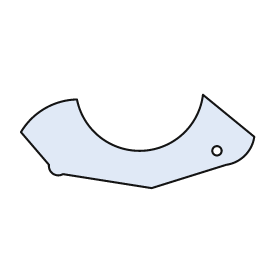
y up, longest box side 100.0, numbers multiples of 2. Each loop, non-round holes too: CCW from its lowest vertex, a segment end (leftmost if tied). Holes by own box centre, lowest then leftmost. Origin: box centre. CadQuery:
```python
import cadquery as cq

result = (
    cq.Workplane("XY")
    .moveTo(6.0, -20.0)
    .lineTo(38.0, -10.0)
    .threePointArc((46.0, -6.0), (50.0, 2.0))
    .lineTo(28.0, 20.0)
    .threePointArc((2.0, -4.0), (-26.0, 18.0))
    .threePointArc((-40.0, 14.0), (-50.0, 4.0))
    .lineTo(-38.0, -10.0)
    .threePointArc((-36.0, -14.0), (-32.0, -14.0))
    .close()
    .moveTo(34.0, -4.0)
    .circle(2.0)
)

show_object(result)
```